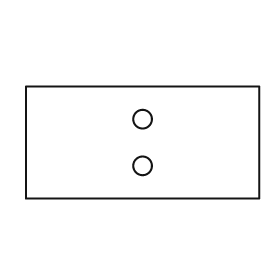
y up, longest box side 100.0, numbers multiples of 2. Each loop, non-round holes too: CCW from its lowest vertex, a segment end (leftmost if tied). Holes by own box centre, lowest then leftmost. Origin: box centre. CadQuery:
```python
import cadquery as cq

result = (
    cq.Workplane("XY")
    .moveTo(-50.0, -24.0)
    .lineTo(50.0, -24.0)
    .lineTo(50.0, 24.0)
    .lineTo(-50.0, 24.0)
    .close()
    .moveTo(0.0, -10.0)
    .circle(4.0)
    .moveTo(0.0, 10.0)
    .circle(4.0)
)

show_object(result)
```